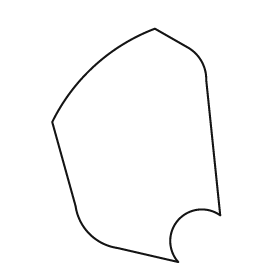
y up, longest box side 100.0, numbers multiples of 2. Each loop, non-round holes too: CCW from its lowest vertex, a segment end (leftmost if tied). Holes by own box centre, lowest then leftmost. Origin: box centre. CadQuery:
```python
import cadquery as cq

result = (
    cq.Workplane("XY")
    .moveTo(18.0, -50.0)
    .threePointArc((18.0, -32.0), (36.0, -30.0))
    .lineTo(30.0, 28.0)
    .threePointArc((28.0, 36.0), (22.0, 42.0))
    .lineTo(8.0, 50.0)
    .threePointArc((-18.0, 34.0), (-36.0, 10.0))
    .lineTo(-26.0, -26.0)
    .threePointArc((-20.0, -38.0), (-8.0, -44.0))
    .close()
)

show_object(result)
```